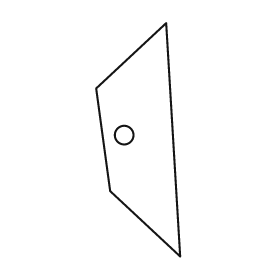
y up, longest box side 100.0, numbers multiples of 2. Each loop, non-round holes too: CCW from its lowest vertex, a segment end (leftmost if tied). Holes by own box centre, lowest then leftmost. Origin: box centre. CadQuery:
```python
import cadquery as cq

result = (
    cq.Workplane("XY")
    .moveTo(18.0, -50.0)
    .lineTo(12.0, 50.0)
    .lineTo(-18.0, 22.0)
    .lineTo(-12.0, -22.0)
    .close()
    .moveTo(-6.0, 2.0)
    .circle(4.0)
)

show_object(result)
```